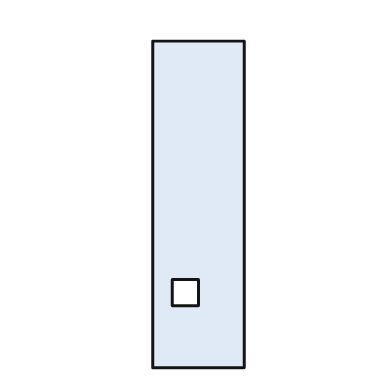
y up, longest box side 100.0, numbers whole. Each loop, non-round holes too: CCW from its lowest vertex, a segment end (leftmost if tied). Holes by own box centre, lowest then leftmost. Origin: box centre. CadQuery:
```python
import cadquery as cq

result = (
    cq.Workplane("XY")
    .moveTo(-14.0, -50.0)
    .lineTo(14.0, -50.0)
    .lineTo(14.0, 50.0)
    .lineTo(-14.0, 50.0)
    .close()
    .moveTo(-8.0, -31.0)
    .lineTo(0.0, -31.0)
    .lineTo(0.0, -23.0)
    .lineTo(-8.0, -23.0)
    .close()
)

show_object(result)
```